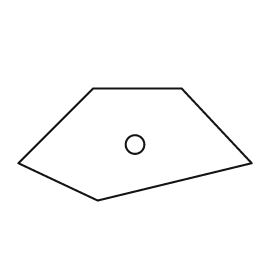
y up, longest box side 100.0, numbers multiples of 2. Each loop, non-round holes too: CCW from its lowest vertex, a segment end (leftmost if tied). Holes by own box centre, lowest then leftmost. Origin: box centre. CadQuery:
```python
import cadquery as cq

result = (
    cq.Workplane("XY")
    .moveTo(-16.0, -24.0)
    .lineTo(50.0, -8.0)
    .lineTo(20.0, 24.0)
    .lineTo(-18.0, 24.0)
    .lineTo(-50.0, -8.0)
    .close()
    .moveTo(0.0, 0.0)
    .circle(4.0)
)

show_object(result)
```